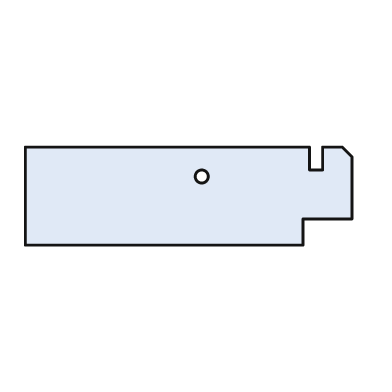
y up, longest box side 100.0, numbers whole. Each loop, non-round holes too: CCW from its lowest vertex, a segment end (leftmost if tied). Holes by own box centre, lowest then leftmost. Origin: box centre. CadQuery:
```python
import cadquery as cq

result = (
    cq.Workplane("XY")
    .moveTo(-50.0, -15.0)
    .lineTo(35.0, -15.0)
    .lineTo(35.0, -7.0)
    .lineTo(50.0, -7.0)
    .lineTo(50.0, 12.0)
    .lineTo(47.0, 15.0)
    .lineTo(41.0, 15.0)
    .lineTo(41.0, 8.0)
    .lineTo(37.0, 8.0)
    .lineTo(37.0, 15.0)
    .lineTo(-50.0, 15.0)
    .close()
    .moveTo(4.0, 6.0)
    .circle(2.0)
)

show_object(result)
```